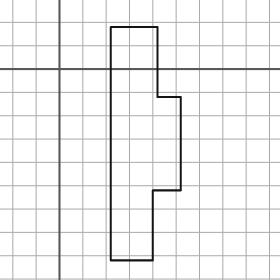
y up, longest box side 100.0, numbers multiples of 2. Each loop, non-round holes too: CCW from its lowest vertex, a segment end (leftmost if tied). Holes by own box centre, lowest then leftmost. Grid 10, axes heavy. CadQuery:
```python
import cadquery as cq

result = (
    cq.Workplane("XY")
    .moveTo(22.0, -82.0)
    .lineTo(40.0, -82.0)
    .lineTo(40.0, -52.0)
    .lineTo(52.0, -52.0)
    .lineTo(52.0, -12.0)
    .lineTo(42.0, -12.0)
    .lineTo(42.0, 18.0)
    .lineTo(22.0, 18.0)
    .close()
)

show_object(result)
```